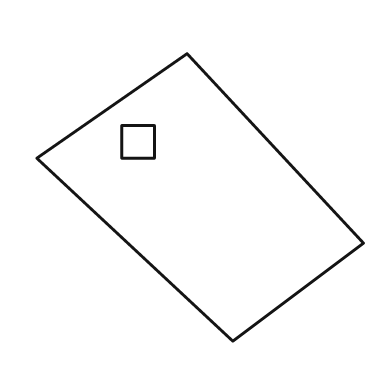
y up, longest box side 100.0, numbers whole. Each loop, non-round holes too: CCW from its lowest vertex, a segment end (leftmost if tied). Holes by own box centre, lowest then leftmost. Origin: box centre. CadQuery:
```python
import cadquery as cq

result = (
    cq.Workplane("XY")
    .moveTo(10.0, -44.0)
    .lineTo(50.0, -14.0)
    .lineTo(-4.0, 44.0)
    .lineTo(-50.0, 12.0)
    .close()
    .moveTo(-24.0, 12.0)
    .lineTo(-14.0, 12.0)
    .lineTo(-14.0, 22.0)
    .lineTo(-24.0, 22.0)
    .close()
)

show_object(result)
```